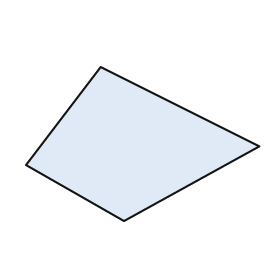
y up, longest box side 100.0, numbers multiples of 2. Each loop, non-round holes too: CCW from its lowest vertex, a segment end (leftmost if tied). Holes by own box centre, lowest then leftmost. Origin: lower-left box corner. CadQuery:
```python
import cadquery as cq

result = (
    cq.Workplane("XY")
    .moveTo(42.0, 0.0)
    .lineTo(100.0, 32.0)
    .lineTo(32.0, 66.0)
    .lineTo(0.0, 24.0)
    .close()
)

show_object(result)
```